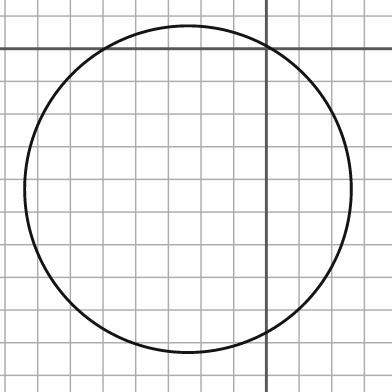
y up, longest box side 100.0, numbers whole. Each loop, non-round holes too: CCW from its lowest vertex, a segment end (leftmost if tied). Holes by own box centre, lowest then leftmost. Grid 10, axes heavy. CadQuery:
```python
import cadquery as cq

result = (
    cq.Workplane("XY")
    .moveTo(-24.0, -43.0)
    .circle(50.0)
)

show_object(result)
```